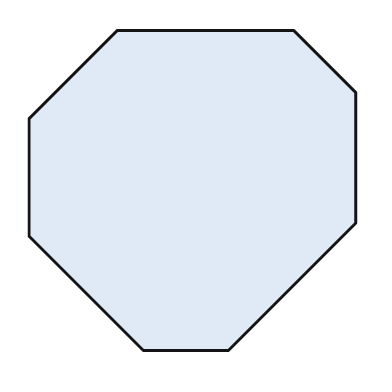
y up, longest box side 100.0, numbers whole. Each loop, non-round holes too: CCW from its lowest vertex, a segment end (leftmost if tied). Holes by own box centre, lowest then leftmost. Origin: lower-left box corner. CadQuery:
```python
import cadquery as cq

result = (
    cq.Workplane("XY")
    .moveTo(35.0, 0.0)
    .lineTo(61.0, 0.0)
    .lineTo(100.0, 39.0)
    .lineTo(100.0, 79.0)
    .lineTo(81.0, 98.0)
    .lineTo(27.0, 98.0)
    .lineTo(0.0, 71.0)
    .lineTo(0.0, 35.0)
    .close()
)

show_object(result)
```